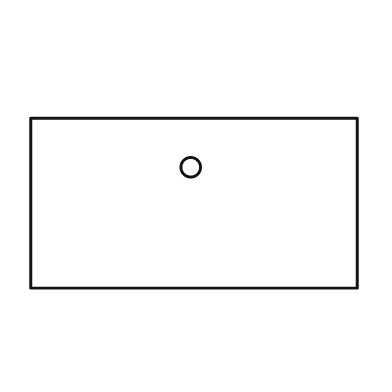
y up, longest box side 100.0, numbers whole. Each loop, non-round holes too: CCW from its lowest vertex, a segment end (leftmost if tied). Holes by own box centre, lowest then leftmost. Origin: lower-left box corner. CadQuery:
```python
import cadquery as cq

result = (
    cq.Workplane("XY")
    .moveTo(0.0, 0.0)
    .lineTo(100.0, 0.0)
    .lineTo(100.0, 52.0)
    .lineTo(0.0, 52.0)
    .close()
    .moveTo(49.0, 37.0)
    .circle(3.0)
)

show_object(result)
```